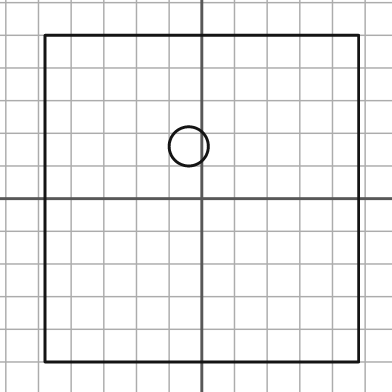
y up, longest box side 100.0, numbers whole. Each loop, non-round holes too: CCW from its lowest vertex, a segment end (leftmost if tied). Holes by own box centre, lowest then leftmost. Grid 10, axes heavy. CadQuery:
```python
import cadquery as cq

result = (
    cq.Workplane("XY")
    .moveTo(-48.0, -50.0)
    .lineTo(48.0, -50.0)
    .lineTo(48.0, 50.0)
    .lineTo(-48.0, 50.0)
    .close()
    .moveTo(-4.0, 16.0)
    .circle(6.0)
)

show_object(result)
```